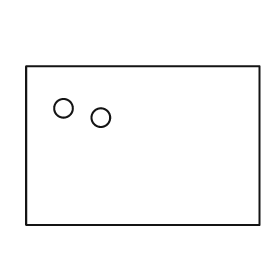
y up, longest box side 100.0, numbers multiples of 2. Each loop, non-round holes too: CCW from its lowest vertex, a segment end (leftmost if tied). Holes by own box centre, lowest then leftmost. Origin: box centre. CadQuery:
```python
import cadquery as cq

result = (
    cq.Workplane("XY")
    .moveTo(-50.0, -34.0)
    .lineTo(50.0, -34.0)
    .lineTo(50.0, 34.0)
    .lineTo(-50.0, 34.0)
    .close()
    .moveTo(-18.0, 12.0)
    .circle(4.0)
    .moveTo(-34.0, 16.0)
    .circle(4.0)
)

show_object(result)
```